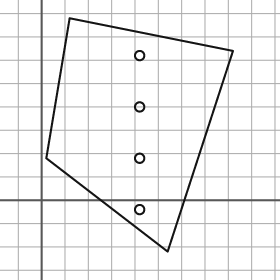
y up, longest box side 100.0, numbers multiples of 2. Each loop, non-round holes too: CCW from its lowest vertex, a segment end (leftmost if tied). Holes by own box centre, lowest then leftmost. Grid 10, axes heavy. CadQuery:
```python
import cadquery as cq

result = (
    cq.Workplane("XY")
    .moveTo(54.0, -22.0)
    .lineTo(82.0, 64.0)
    .lineTo(12.0, 78.0)
    .lineTo(2.0, 18.0)
    .close()
    .moveTo(42.0, -4.0)
    .circle(2.0)
    .moveTo(42.0, 18.0)
    .circle(2.0)
    .moveTo(42.0, 40.0)
    .circle(2.0)
    .moveTo(42.0, 62.0)
    .circle(2.0)
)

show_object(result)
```